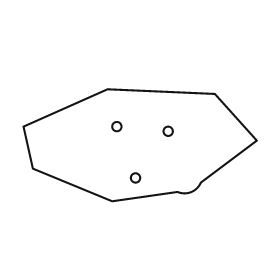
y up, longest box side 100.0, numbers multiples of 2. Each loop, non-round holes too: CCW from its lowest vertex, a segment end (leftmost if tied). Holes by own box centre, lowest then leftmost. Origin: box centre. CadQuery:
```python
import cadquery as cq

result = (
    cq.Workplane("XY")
    .moveTo(-12.0, -24.0)
    .lineTo(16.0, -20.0)
    .threePointArc((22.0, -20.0), (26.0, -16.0))
    .lineTo(50.0, 2.0)
    .lineTo(32.0, 22.0)
    .lineTo(-14.0, 24.0)
    .lineTo(-50.0, 8.0)
    .lineTo(-46.0, -10.0)
    .close()
    .moveTo(-2.0, -14.0)
    .circle(2.0)
    .moveTo(12.0, 6.0)
    .circle(2.0)
    .moveTo(-10.0, 8.0)
    .circle(2.0)
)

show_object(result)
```